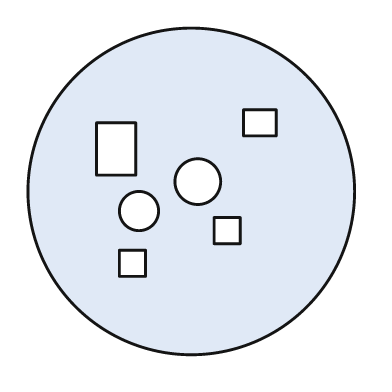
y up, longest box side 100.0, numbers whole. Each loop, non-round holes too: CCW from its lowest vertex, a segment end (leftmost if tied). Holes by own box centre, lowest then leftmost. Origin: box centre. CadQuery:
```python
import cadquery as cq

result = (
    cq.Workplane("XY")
    .moveTo(0.0, 0.0)
    .circle(50.0)
    .moveTo(-22.0, -26.0)
    .lineTo(-14.0, -26.0)
    .lineTo(-14.0, -18.0)
    .lineTo(-22.0, -18.0)
    .close()
    .moveTo(7.0, -16.0)
    .lineTo(15.0, -16.0)
    .lineTo(15.0, -8.0)
    .lineTo(7.0, -8.0)
    .close()
    .moveTo(-16.0, -6.0)
    .circle(6.0)
    .moveTo(2.0, 3.0)
    .circle(7.0)
    .moveTo(-29.0, 5.0)
    .lineTo(-17.0, 5.0)
    .lineTo(-17.0, 21.0)
    .lineTo(-29.0, 21.0)
    .close()
    .moveTo(16.0, 17.0)
    .lineTo(26.0, 17.0)
    .lineTo(26.0, 25.0)
    .lineTo(16.0, 25.0)
    .close()
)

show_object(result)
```